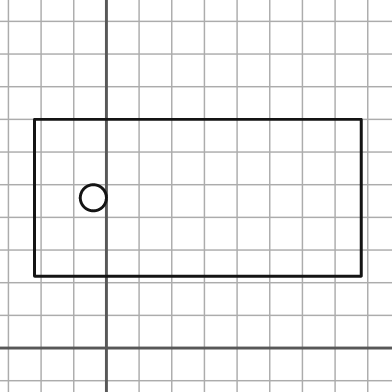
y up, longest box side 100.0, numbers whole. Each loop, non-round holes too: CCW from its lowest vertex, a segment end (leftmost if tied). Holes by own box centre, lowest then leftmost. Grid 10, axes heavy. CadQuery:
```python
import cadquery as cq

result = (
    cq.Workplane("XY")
    .moveTo(-22.0, 22.0)
    .lineTo(78.0, 22.0)
    .lineTo(78.0, 70.0)
    .lineTo(-22.0, 70.0)
    .close()
    .moveTo(-4.0, 46.0)
    .circle(4.0)
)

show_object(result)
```